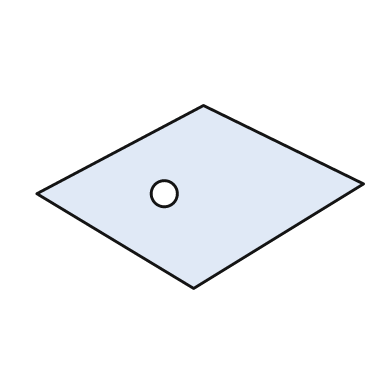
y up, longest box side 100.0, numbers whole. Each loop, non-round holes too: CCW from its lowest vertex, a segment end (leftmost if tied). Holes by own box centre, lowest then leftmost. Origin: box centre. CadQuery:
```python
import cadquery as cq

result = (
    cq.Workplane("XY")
    .moveTo(-2.0, -28.0)
    .lineTo(50.0, 4.0)
    .lineTo(1.0, 28.0)
    .lineTo(-50.0, 1.0)
    .close()
    .moveTo(-11.0, 1.0)
    .circle(4.0)
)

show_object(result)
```